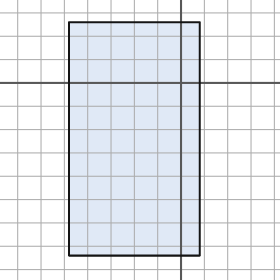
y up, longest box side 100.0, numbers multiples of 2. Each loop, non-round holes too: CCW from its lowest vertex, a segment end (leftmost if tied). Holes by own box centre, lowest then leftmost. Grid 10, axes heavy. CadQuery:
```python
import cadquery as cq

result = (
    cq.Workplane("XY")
    .moveTo(-48.0, -74.0)
    .lineTo(8.0, -74.0)
    .lineTo(8.0, 26.0)
    .lineTo(-48.0, 26.0)
    .close()
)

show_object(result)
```